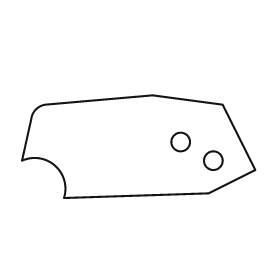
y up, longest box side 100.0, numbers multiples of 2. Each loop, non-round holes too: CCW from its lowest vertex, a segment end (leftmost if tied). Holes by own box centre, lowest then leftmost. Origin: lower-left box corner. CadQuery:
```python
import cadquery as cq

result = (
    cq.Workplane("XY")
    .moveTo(18.0, 0.0)
    .lineTo(80.0, 2.0)
    .lineTo(100.0, 12.0)
    .lineTo(86.0, 40.0)
    .lineTo(56.0, 44.0)
    .lineTo(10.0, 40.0)
    .threePointArc((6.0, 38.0), (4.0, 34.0))
    .lineTo(0.0, 16.0)
    .threePointArc((14.0, 14.0), (18.0, 0.0))
    .close()
    .moveTo(82.0, 16.0)
    .circle(4.0)
    .moveTo(68.0, 24.0)
    .circle(4.0)
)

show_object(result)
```